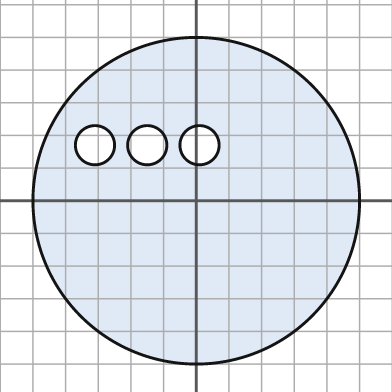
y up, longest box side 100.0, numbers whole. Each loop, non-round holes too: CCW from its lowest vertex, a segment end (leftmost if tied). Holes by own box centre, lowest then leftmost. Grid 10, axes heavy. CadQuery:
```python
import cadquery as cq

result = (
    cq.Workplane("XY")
    .moveTo(0.0, 0.0)
    .circle(50.0)
    .moveTo(-31.0, 17.0)
    .circle(6.0)
    .moveTo(-15.0, 17.0)
    .circle(6.0)
    .moveTo(1.0, 17.0)
    .circle(6.0)
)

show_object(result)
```